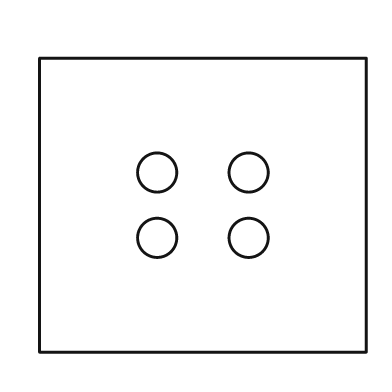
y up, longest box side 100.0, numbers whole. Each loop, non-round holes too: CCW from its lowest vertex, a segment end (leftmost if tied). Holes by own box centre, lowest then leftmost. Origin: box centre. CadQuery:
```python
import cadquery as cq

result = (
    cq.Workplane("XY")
    .moveTo(-50.0, -45.0)
    .lineTo(50.0, -45.0)
    .lineTo(50.0, 45.0)
    .lineTo(-50.0, 45.0)
    .close()
    .moveTo(-14.0, -10.0)
    .circle(6.0)
    .moveTo(14.0, -10.0)
    .circle(6.0)
    .moveTo(-14.0, 10.0)
    .circle(6.0)
    .moveTo(14.0, 10.0)
    .circle(6.0)
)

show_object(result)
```